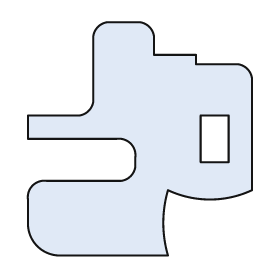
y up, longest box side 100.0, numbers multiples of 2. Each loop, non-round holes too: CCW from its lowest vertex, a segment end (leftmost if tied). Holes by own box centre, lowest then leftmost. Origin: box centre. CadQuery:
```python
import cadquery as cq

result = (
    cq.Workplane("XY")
    .moveTo(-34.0, -50.0)
    .lineTo(12.0, -50.0)
    .threePointArc((10.0, -36.0), (12.0, -22.0))
    .threePointArc((30.0, -26.0), (48.0, -22.0))
    .lineTo(48.0, 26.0)
    .threePointArc((46.0, 30.0), (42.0, 32.0))
    .lineTo(24.0, 32.0)
    .lineTo(24.0, 36.0)
    .lineTo(6.0, 36.0)
    .lineTo(6.0, 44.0)
    .threePointArc((4.0, 48.0), (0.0, 50.0))
    .lineTo(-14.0, 50.0)
    .threePointArc((-18.0, 48.0), (-20.0, 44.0))
    .lineTo(-20.0, 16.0)
    .threePointArc((-22.0, 12.0), (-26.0, 10.0))
    .lineTo(-48.0, 10.0)
    .lineTo(-48.0, 0.0)
    .lineTo(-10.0, 0.0)
    .threePointArc((-4.0, -2.0), (-2.0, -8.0))
    .lineTo(-2.0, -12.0)
    .threePointArc((-4.0, -16.0), (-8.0, -18.0))
    .lineTo(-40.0, -18.0)
    .threePointArc((-46.0, -20.0), (-48.0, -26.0))
    .lineTo(-48.0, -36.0)
    .threePointArc((-44.0, -46.0), (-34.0, -50.0))
    .close()
    .moveTo(26.0, -10.0)
    .lineTo(38.0, -10.0)
    .lineTo(38.0, 10.0)
    .lineTo(26.0, 10.0)
    .close()
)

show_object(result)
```